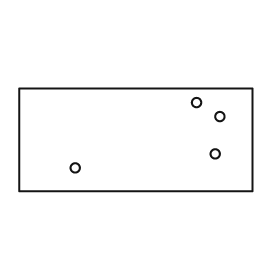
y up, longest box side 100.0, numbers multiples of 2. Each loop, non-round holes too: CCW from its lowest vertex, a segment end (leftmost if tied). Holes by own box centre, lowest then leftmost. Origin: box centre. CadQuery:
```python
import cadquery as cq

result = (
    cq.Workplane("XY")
    .moveTo(-50.0, -22.0)
    .lineTo(50.0, -22.0)
    .lineTo(50.0, 22.0)
    .lineTo(-50.0, 22.0)
    .close()
    .moveTo(-26.0, -12.0)
    .circle(2.0)
    .moveTo(34.0, -6.0)
    .circle(2.0)
    .moveTo(36.0, 10.0)
    .circle(2.0)
    .moveTo(26.0, 16.0)
    .circle(2.0)
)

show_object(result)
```